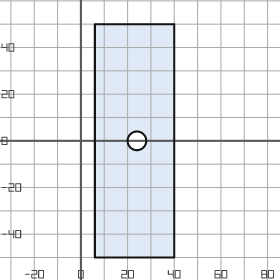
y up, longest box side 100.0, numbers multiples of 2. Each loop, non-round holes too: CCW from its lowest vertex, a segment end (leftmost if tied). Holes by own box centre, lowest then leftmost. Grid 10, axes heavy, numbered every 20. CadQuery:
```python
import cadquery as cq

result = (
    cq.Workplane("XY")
    .moveTo(6.0, -50.0)
    .lineTo(40.0, -50.0)
    .lineTo(40.0, 50.0)
    .lineTo(6.0, 50.0)
    .close()
    .moveTo(24.0, 0.0)
    .circle(4.0)
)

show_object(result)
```